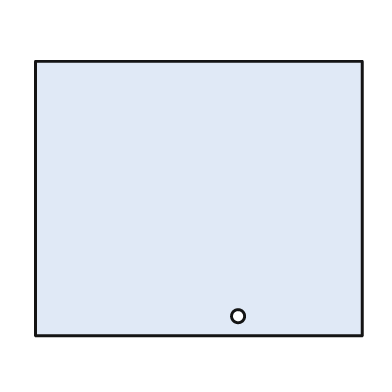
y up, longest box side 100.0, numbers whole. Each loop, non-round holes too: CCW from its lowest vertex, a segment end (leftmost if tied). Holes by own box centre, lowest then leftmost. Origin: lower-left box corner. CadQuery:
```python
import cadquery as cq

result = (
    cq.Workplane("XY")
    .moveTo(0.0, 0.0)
    .lineTo(100.0, 0.0)
    .lineTo(100.0, 84.0)
    .lineTo(0.0, 84.0)
    .close()
    .moveTo(62.0, 6.0)
    .circle(2.0)
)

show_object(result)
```